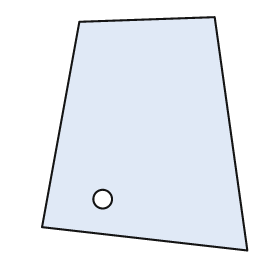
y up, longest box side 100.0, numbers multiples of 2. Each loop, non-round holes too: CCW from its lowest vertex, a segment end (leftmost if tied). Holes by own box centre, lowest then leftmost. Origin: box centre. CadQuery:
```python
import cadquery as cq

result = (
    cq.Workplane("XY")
    .moveTo(44.0, -50.0)
    .lineTo(30.0, 50.0)
    .lineTo(-28.0, 48.0)
    .lineTo(-44.0, -40.0)
    .close()
    .moveTo(-18.0, -28.0)
    .circle(4.0)
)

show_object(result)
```